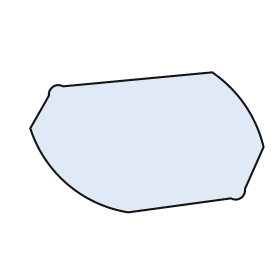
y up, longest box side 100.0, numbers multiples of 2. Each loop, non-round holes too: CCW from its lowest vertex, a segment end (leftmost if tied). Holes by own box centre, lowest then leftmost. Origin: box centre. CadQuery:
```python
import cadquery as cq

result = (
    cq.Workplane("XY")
    .moveTo(-8.0, -30.0)
    .lineTo(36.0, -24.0)
    .threePointArc((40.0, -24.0), (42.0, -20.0))
    .lineTo(50.0, -2.0)
    .threePointArc((42.0, 16.0), (28.0, 30.0))
    .lineTo(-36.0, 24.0)
    .threePointArc((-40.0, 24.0), (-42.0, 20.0))
    .lineTo(-50.0, 6.0)
    .threePointArc((-34.0, -18.0), (-8.0, -30.0))
    .close()
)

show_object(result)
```